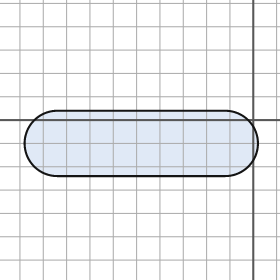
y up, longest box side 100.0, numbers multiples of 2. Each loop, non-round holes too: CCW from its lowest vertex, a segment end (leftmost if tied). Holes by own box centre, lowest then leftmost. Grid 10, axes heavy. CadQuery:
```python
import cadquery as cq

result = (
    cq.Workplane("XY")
    .moveTo(-84.0, -24.0)
    .lineTo(-12.0, -24.0)
    .threePointArc((2.0, -10.0), (-12.0, 4.0))
    .lineTo(-84.0, 4.0)
    .threePointArc((-98.0, -10.0), (-84.0, -24.0))
    .close()
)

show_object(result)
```